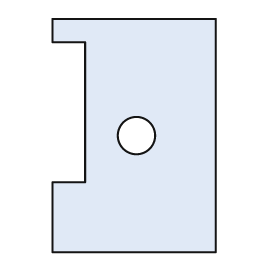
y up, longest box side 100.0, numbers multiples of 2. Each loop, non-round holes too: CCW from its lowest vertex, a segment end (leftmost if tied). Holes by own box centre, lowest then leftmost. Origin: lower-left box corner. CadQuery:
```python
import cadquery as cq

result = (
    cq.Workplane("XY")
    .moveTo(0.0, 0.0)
    .lineTo(70.0, 0.0)
    .lineTo(70.0, 100.0)
    .lineTo(0.0, 100.0)
    .lineTo(0.0, 90.0)
    .lineTo(14.0, 90.0)
    .lineTo(14.0, 30.0)
    .lineTo(0.0, 30.0)
    .close()
    .moveTo(36.0, 50.0)
    .circle(8.0)
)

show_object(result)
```